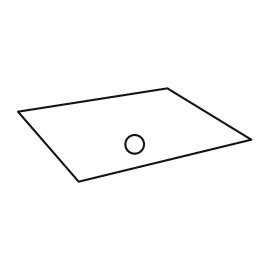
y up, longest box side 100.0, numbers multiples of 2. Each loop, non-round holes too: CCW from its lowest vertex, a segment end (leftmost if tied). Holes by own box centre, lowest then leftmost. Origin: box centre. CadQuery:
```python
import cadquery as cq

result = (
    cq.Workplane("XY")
    .moveTo(-24.0, -20.0)
    .lineTo(50.0, -2.0)
    .lineTo(14.0, 20.0)
    .lineTo(-50.0, 10.0)
    .close()
    .moveTo(0.0, -4.0)
    .circle(4.0)
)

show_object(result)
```